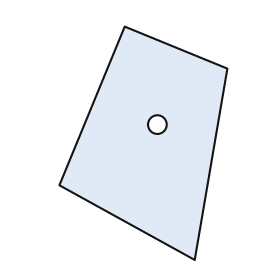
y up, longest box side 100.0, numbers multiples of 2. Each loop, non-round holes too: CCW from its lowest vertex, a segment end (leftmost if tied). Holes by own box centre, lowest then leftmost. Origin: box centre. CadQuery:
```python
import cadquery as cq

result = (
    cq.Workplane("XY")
    .moveTo(22.0, -50.0)
    .lineTo(36.0, 32.0)
    .lineTo(-8.0, 50.0)
    .lineTo(-36.0, -18.0)
    .close()
    .moveTo(6.0, 8.0)
    .circle(4.0)
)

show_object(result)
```